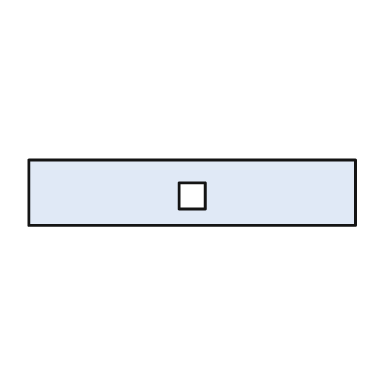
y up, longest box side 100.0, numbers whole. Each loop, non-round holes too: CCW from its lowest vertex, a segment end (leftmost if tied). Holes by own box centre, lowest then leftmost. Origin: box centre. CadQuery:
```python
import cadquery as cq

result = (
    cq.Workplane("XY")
    .moveTo(-50.0, -10.0)
    .lineTo(50.0, -10.0)
    .lineTo(50.0, 10.0)
    .lineTo(-50.0, 10.0)
    .close()
    .moveTo(-4.0, -5.0)
    .lineTo(4.0, -5.0)
    .lineTo(4.0, 3.0)
    .lineTo(-4.0, 3.0)
    .close()
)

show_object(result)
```